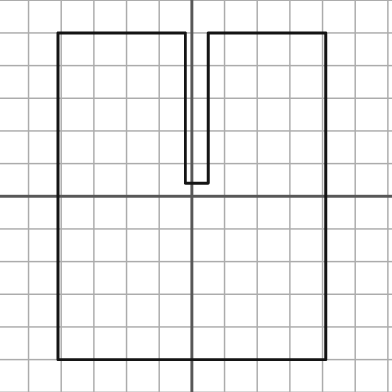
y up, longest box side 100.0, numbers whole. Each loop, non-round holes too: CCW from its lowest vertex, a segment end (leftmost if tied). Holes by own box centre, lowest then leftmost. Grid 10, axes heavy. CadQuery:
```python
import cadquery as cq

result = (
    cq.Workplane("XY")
    .moveTo(-41.0, -50.0)
    .lineTo(41.0, -50.0)
    .lineTo(41.0, 50.0)
    .lineTo(5.0, 50.0)
    .lineTo(5.0, 4.0)
    .lineTo(-2.0, 4.0)
    .lineTo(-2.0, 50.0)
    .lineTo(-41.0, 50.0)
    .close()
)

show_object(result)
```